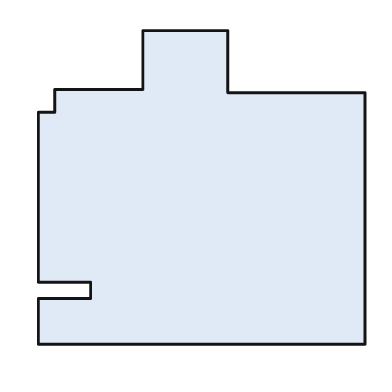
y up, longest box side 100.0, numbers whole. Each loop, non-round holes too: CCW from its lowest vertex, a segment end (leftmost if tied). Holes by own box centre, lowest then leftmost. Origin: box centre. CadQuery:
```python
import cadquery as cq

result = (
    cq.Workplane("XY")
    .moveTo(-50.0, -48.0)
    .lineTo(50.0, -48.0)
    .lineTo(50.0, 29.0)
    .lineTo(8.0, 29.0)
    .lineTo(8.0, 48.0)
    .lineTo(-18.0, 48.0)
    .lineTo(-18.0, 30.0)
    .lineTo(-45.0, 30.0)
    .lineTo(-45.0, 23.0)
    .lineTo(-50.0, 23.0)
    .lineTo(-50.0, -29.0)
    .lineTo(-34.0, -29.0)
    .lineTo(-34.0, -34.0)
    .lineTo(-50.0, -34.0)
    .close()
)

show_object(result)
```